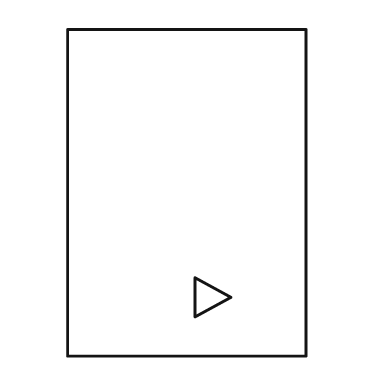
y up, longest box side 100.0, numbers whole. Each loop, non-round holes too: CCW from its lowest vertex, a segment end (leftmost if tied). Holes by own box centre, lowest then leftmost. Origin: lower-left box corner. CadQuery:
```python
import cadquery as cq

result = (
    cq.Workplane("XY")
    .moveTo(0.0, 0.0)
    .lineTo(73.0, 0.0)
    .lineTo(73.0, 100.0)
    .lineTo(0.0, 100.0)
    .close()
    .moveTo(39.0, 12.0)
    .lineTo(50.0, 18.0)
    .lineTo(39.0, 24.0)
    .close()
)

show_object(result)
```